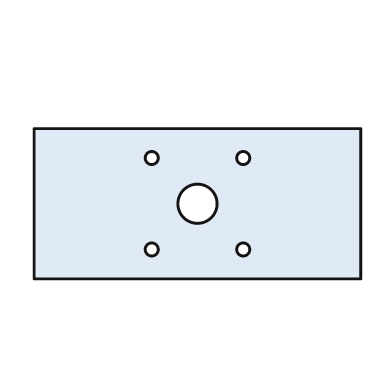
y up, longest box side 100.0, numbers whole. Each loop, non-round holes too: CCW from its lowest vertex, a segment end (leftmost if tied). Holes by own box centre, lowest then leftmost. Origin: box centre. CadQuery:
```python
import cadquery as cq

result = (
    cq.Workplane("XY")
    .moveTo(-50.0, -23.0)
    .lineTo(50.0, -23.0)
    .lineTo(50.0, 23.0)
    .lineTo(-50.0, 23.0)
    .close()
    .moveTo(-14.0, -14.0)
    .circle(2.0)
    .moveTo(14.0, -14.0)
    .circle(2.0)
    .moveTo(0.0, 0.0)
    .circle(6.0)
    .moveTo(-14.0, 14.0)
    .circle(2.0)
    .moveTo(14.0, 14.0)
    .circle(2.0)
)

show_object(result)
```